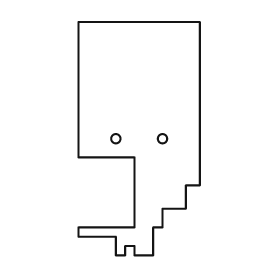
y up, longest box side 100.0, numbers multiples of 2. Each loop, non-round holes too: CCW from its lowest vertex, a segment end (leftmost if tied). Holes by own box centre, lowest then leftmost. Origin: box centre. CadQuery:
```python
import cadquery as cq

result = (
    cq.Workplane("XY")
    .moveTo(-10.0, -50.0)
    .lineTo(-6.0, -50.0)
    .lineTo(-6.0, -46.0)
    .lineTo(-2.0, -46.0)
    .lineTo(-2.0, -50.0)
    .lineTo(6.0, -50.0)
    .lineTo(6.0, -38.0)
    .lineTo(10.0, -38.0)
    .lineTo(10.0, -30.0)
    .lineTo(20.0, -30.0)
    .lineTo(20.0, -20.0)
    .lineTo(26.0, -20.0)
    .lineTo(26.0, 50.0)
    .lineTo(-26.0, 50.0)
    .lineTo(-26.0, -8.0)
    .lineTo(-2.0, -8.0)
    .lineTo(-2.0, -38.0)
    .lineTo(-26.0, -38.0)
    .lineTo(-26.0, -42.0)
    .lineTo(-10.0, -42.0)
    .close()
    .moveTo(-10.0, 0.0)
    .circle(2.0)
    .moveTo(10.0, 0.0)
    .circle(2.0)
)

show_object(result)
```